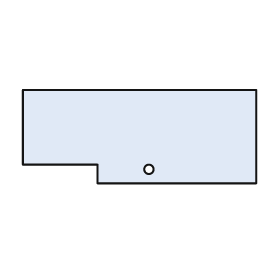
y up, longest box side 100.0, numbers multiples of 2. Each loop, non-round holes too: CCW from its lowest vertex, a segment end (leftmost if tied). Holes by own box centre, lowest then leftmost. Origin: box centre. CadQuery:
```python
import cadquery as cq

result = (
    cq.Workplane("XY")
    .moveTo(-18.0, -20.0)
    .lineTo(50.0, -20.0)
    .lineTo(50.0, 20.0)
    .lineTo(-50.0, 20.0)
    .lineTo(-50.0, -12.0)
    .lineTo(-18.0, -12.0)
    .close()
    .moveTo(4.0, -14.0)
    .circle(2.0)
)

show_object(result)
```